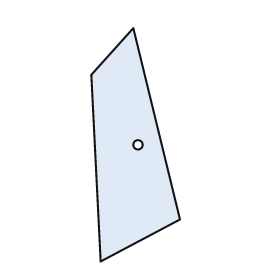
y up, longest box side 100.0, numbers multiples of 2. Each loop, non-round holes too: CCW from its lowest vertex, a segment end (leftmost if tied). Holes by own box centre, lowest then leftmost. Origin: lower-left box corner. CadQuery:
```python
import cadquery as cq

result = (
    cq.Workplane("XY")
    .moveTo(4.0, 0.0)
    .lineTo(38.0, 18.0)
    .lineTo(18.0, 100.0)
    .lineTo(0.0, 80.0)
    .close()
    .moveTo(20.0, 50.0)
    .circle(2.0)
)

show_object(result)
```